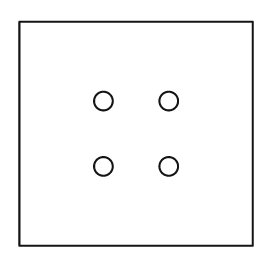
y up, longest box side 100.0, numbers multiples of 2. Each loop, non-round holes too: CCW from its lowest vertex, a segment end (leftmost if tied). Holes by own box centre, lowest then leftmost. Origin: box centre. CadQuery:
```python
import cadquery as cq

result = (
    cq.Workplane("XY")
    .moveTo(-50.0, -48.0)
    .lineTo(50.0, -48.0)
    .lineTo(50.0, 48.0)
    .lineTo(-50.0, 48.0)
    .close()
    .moveTo(-14.0, -14.0)
    .circle(4.0)
    .moveTo(14.0, -14.0)
    .circle(4.0)
    .moveTo(-14.0, 14.0)
    .circle(4.0)
    .moveTo(14.0, 14.0)
    .circle(4.0)
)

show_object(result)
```